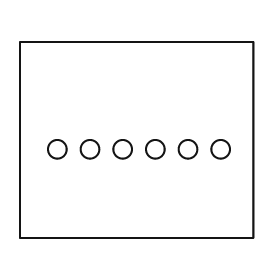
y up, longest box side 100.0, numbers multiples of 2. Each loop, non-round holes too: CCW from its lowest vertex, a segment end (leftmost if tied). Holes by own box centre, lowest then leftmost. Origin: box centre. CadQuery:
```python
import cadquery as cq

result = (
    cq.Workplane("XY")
    .moveTo(-50.0, -42.0)
    .lineTo(50.0, -42.0)
    .lineTo(50.0, 42.0)
    .lineTo(-50.0, 42.0)
    .close()
    .moveTo(-34.0, -4.0)
    .circle(4.0)
    .moveTo(-20.0, -4.0)
    .circle(4.0)
    .moveTo(-6.0, -4.0)
    .circle(4.0)
    .moveTo(8.0, -4.0)
    .circle(4.0)
    .moveTo(22.0, -4.0)
    .circle(4.0)
    .moveTo(36.0, -4.0)
    .circle(4.0)
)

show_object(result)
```